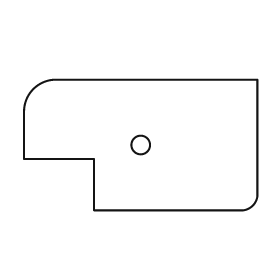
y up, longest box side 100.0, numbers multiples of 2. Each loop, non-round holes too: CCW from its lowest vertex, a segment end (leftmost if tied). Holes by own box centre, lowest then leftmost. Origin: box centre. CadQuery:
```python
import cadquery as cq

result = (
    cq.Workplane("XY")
    .moveTo(-20.0, -28.0)
    .lineTo(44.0, -28.0)
    .threePointArc((48.0, -26.0), (50.0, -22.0))
    .lineTo(50.0, 28.0)
    .lineTo(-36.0, 28.0)
    .threePointArc((-46.0, 24.0), (-50.0, 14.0))
    .lineTo(-50.0, -6.0)
    .lineTo(-20.0, -6.0)
    .close()
    .moveTo(0.0, 0.0)
    .circle(4.0)
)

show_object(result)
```